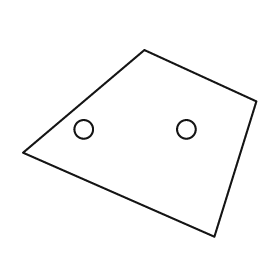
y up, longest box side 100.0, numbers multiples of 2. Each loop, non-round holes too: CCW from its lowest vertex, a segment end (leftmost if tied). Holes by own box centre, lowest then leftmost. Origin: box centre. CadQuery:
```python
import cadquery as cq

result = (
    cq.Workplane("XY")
    .moveTo(32.0, -40.0)
    .lineTo(50.0, 18.0)
    .lineTo(2.0, 40.0)
    .lineTo(-50.0, -4.0)
    .close()
    .moveTo(-24.0, 6.0)
    .circle(4.0)
    .moveTo(20.0, 6.0)
    .circle(4.0)
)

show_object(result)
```